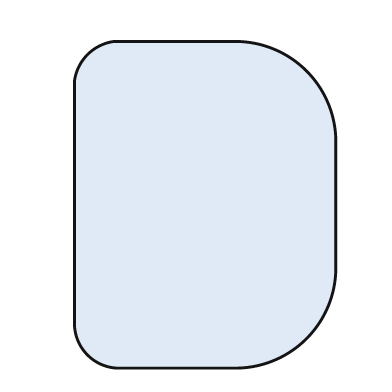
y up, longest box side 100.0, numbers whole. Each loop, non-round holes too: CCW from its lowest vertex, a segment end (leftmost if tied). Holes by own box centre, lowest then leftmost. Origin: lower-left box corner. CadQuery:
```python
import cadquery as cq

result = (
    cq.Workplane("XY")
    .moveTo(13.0, 0.0)
    .lineTo(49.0, 0.0)
    .threePointArc((71.0, 9.0), (80.0, 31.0))
    .lineTo(80.0, 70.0)
    .threePointArc((71.0, 91.0), (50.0, 100.0))
    .lineTo(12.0, 100.0)
    .threePointArc((4.0, 96.0), (0.0, 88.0))
    .lineTo(0.0, 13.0)
    .threePointArc((4.0, 4.0), (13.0, 0.0))
    .close()
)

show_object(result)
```